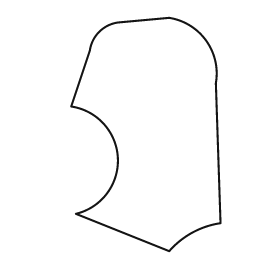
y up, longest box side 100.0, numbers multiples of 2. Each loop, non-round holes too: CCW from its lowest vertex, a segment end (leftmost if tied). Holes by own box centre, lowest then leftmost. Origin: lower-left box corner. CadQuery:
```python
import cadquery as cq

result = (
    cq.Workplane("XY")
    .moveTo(42.0, 0.0)
    .threePointArc((52.0, 8.0), (64.0, 12.0))
    .lineTo(62.0, 72.0)
    .threePointArc((58.0, 90.0), (42.0, 100.0))
    .lineTo(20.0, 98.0)
    .threePointArc((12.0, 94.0), (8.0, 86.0))
    .lineTo(0.0, 62.0)
    .threePointArc((20.0, 40.0), (2.0, 16.0))
    .close()
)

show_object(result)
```